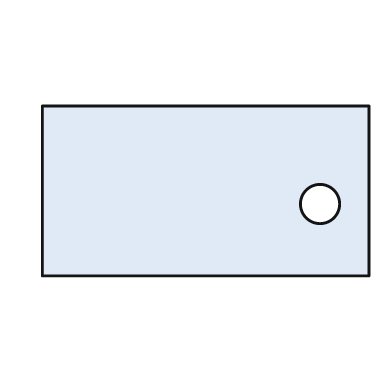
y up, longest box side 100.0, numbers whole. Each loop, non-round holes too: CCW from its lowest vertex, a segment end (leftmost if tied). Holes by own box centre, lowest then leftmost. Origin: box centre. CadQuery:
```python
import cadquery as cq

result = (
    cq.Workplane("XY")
    .moveTo(-50.0, -26.0)
    .lineTo(50.0, -26.0)
    .lineTo(50.0, 26.0)
    .lineTo(-50.0, 26.0)
    .close()
    .moveTo(35.0, -4.0)
    .circle(6.0)
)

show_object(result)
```